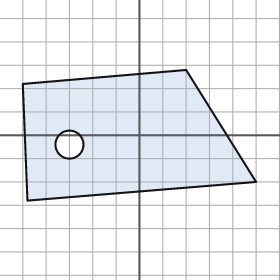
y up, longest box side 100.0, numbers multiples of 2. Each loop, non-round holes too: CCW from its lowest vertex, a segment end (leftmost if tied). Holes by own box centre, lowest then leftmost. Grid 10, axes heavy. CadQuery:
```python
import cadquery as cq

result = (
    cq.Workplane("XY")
    .moveTo(-48.0, -28.0)
    .lineTo(50.0, -20.0)
    .lineTo(20.0, 28.0)
    .lineTo(-50.0, 22.0)
    .close()
    .moveTo(-30.0, -4.0)
    .circle(6.0)
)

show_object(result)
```